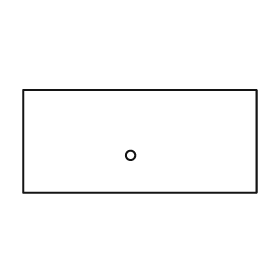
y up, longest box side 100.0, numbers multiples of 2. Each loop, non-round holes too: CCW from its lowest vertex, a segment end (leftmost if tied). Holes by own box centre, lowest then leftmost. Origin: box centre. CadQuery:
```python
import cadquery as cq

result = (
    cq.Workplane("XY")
    .moveTo(-50.0, -22.0)
    .lineTo(50.0, -22.0)
    .lineTo(50.0, 22.0)
    .lineTo(-50.0, 22.0)
    .close()
    .moveTo(-4.0, -6.0)
    .circle(2.0)
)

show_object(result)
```